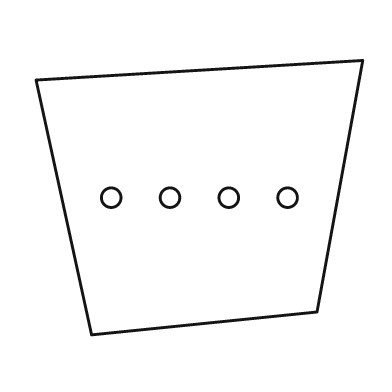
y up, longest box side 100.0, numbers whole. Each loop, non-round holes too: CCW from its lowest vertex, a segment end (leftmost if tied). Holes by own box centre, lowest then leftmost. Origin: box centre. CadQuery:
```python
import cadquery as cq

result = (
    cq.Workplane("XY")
    .moveTo(-33.0, -42.0)
    .lineTo(36.0, -35.0)
    .lineTo(50.0, 42.0)
    .lineTo(-50.0, 36.0)
    .close()
    .moveTo(-27.0, 0.0)
    .circle(3.0)
    .moveTo(-9.0, 0.0)
    .circle(3.0)
    .moveTo(9.0, 0.0)
    .circle(3.0)
    .moveTo(27.0, 0.0)
    .circle(3.0)
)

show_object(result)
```